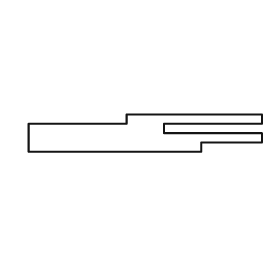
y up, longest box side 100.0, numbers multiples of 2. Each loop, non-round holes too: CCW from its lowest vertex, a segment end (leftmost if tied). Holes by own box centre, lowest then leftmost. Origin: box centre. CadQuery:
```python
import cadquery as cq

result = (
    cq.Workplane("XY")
    .moveTo(-50.0, -8.0)
    .lineTo(24.0, -8.0)
    .lineTo(24.0, -4.0)
    .lineTo(50.0, -4.0)
    .lineTo(50.0, 0.0)
    .lineTo(8.0, 0.0)
    .lineTo(8.0, 4.0)
    .lineTo(50.0, 4.0)
    .lineTo(50.0, 8.0)
    .lineTo(-8.0, 8.0)
    .lineTo(-8.0, 4.0)
    .lineTo(-50.0, 4.0)
    .close()
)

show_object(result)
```